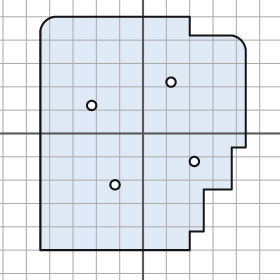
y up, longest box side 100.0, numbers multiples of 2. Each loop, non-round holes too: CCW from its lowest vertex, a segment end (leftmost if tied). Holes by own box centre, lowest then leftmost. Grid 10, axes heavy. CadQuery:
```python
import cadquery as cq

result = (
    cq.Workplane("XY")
    .moveTo(-44.0, -50.0)
    .lineTo(20.0, -50.0)
    .lineTo(20.0, -42.0)
    .lineTo(26.0, -42.0)
    .lineTo(26.0, -24.0)
    .lineTo(38.0, -24.0)
    .lineTo(38.0, -6.0)
    .lineTo(44.0, -6.0)
    .lineTo(44.0, 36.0)
    .threePointArc((42.0, 40.0), (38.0, 42.0))
    .lineTo(20.0, 42.0)
    .lineTo(20.0, 50.0)
    .lineTo(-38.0, 50.0)
    .threePointArc((-42.0, 48.0), (-44.0, 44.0))
    .close()
    .moveTo(-12.0, -22.0)
    .circle(2.0)
    .moveTo(22.0, -12.0)
    .circle(2.0)
    .moveTo(-22.0, 12.0)
    .circle(2.0)
    .moveTo(12.0, 22.0)
    .circle(2.0)
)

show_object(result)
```